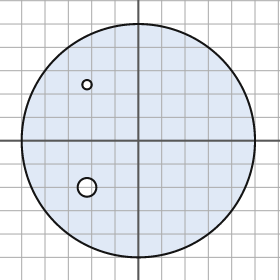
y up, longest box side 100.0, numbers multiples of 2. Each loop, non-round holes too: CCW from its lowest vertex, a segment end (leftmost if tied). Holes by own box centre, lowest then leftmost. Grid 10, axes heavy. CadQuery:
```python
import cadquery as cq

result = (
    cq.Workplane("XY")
    .moveTo(0.0, 0.0)
    .circle(50.0)
    .moveTo(-22.0, -20.0)
    .circle(4.0)
    .moveTo(-22.0, 24.0)
    .circle(2.0)
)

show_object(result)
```